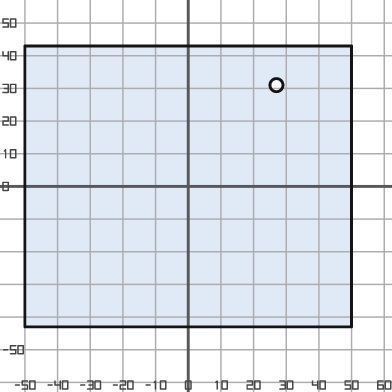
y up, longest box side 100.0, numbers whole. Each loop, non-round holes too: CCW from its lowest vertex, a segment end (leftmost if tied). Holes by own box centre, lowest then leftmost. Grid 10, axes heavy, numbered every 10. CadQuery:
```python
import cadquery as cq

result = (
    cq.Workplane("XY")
    .moveTo(-50.0, -43.0)
    .lineTo(50.0, -43.0)
    .lineTo(50.0, 43.0)
    .lineTo(-50.0, 43.0)
    .close()
    .moveTo(27.0, 31.0)
    .circle(2.0)
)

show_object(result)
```